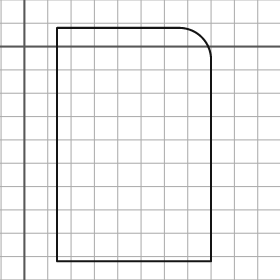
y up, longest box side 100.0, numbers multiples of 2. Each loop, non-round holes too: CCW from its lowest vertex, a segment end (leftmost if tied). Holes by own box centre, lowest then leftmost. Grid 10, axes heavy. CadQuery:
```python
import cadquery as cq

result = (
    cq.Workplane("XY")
    .moveTo(14.0, -92.0)
    .lineTo(80.0, -92.0)
    .lineTo(80.0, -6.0)
    .threePointArc((76.0, 4.0), (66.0, 8.0))
    .lineTo(14.0, 8.0)
    .close()
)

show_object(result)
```